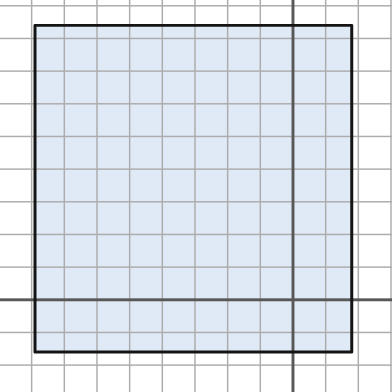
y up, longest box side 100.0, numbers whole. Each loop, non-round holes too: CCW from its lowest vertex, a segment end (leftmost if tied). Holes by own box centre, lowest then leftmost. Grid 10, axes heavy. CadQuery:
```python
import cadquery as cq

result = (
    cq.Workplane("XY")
    .moveTo(-79.0, -16.0)
    .lineTo(18.0, -16.0)
    .lineTo(18.0, 84.0)
    .lineTo(-79.0, 84.0)
    .close()
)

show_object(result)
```